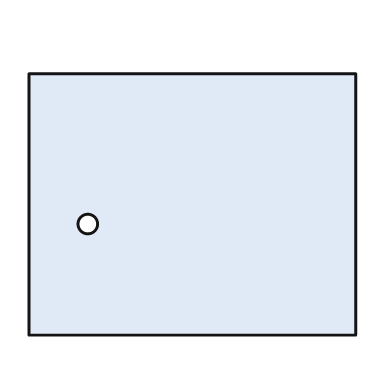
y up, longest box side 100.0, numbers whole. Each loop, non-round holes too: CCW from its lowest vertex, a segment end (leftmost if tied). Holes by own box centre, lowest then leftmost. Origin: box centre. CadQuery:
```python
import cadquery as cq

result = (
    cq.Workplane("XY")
    .moveTo(-50.0, -40.0)
    .lineTo(50.0, -40.0)
    .lineTo(50.0, 40.0)
    .lineTo(-50.0, 40.0)
    .close()
    .moveTo(-32.0, -6.0)
    .circle(3.0)
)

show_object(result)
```